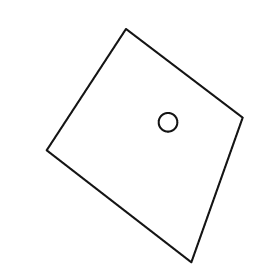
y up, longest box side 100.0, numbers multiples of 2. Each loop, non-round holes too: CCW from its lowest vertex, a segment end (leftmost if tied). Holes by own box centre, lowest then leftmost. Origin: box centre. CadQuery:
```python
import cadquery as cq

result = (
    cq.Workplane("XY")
    .moveTo(20.0, -50.0)
    .lineTo(42.0, 12.0)
    .lineTo(-8.0, 50.0)
    .lineTo(-42.0, -2.0)
    .close()
    .moveTo(10.0, 10.0)
    .circle(4.0)
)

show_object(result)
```